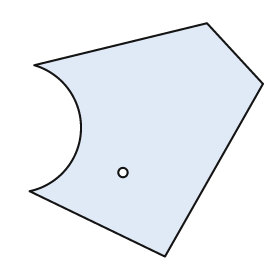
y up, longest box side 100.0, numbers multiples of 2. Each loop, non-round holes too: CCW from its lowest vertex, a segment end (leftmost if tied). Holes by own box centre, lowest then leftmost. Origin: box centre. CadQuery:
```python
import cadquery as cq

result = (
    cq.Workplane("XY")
    .moveTo(8.0, -50.0)
    .lineTo(50.0, 24.0)
    .lineTo(26.0, 50.0)
    .lineTo(-48.0, 32.0)
    .threePointArc((-28.0, 4.0), (-50.0, -22.0))
    .close()
    .moveTo(-10.0, -14.0)
    .circle(2.0)
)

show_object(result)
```